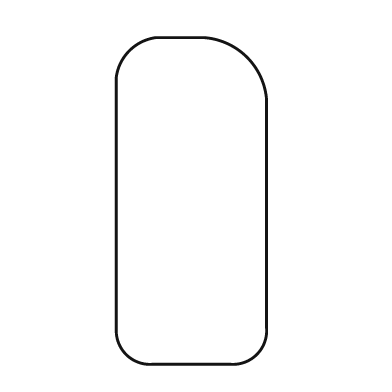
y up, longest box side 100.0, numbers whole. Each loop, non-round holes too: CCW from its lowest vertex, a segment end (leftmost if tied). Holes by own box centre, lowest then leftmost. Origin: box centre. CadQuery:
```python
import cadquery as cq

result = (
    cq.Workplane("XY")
    .moveTo(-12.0, -50.0)
    .lineTo(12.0, -50.0)
    .threePointArc((20.0, -47.0), (23.0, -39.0))
    .lineTo(23.0, 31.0)
    .threePointArc((17.0, 44.0), (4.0, 50.0))
    .lineTo(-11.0, 50.0)
    .threePointArc((-19.0, 46.0), (-23.0, 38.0))
    .lineTo(-23.0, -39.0)
    .threePointArc((-20.0, -47.0), (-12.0, -50.0))
    .close()
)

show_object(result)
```